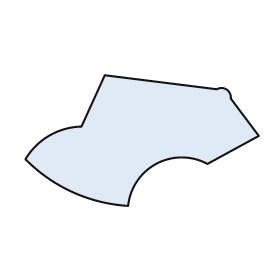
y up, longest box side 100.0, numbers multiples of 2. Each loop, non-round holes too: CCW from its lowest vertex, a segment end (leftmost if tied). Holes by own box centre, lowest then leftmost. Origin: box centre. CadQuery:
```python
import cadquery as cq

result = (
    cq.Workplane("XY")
    .moveTo(-6.0, -28.0)
    .threePointArc((6.0, -10.0), (28.0, -10.0))
    .lineTo(50.0, 2.0)
    .lineTo(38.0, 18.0)
    .threePointArc((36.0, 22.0), (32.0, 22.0))
    .lineTo(-16.0, 28.0)
    .lineTo(-26.0, 6.0)
    .threePointArc((-40.0, 2.0), (-50.0, -8.0))
    .threePointArc((-30.0, -22.0), (-6.0, -28.0))
    .close()
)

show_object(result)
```